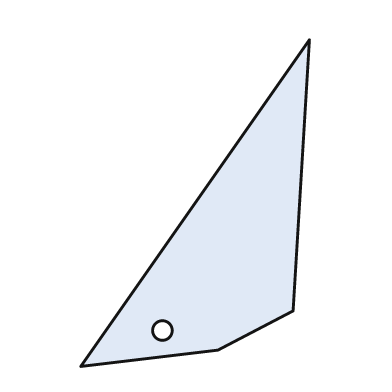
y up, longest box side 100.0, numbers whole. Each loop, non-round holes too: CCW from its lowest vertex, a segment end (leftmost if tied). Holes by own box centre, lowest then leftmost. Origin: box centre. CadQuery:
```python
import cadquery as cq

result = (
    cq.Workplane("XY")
    .moveTo(-35.0, -50.0)
    .lineTo(7.0, -45.0)
    .lineTo(30.0, -33.0)
    .lineTo(35.0, 50.0)
    .close()
    .moveTo(-10.0, -39.0)
    .circle(3.0)
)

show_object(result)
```